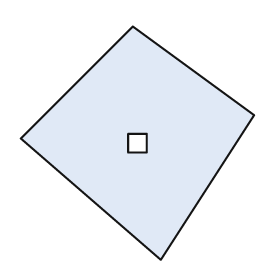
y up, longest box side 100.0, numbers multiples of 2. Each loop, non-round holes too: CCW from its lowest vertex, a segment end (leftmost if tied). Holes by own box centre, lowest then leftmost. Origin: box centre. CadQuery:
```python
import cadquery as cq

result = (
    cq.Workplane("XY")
    .moveTo(10.0, -50.0)
    .lineTo(50.0, 12.0)
    .lineTo(-2.0, 50.0)
    .lineTo(-50.0, 2.0)
    .close()
    .moveTo(-4.0, -4.0)
    .lineTo(4.0, -4.0)
    .lineTo(4.0, 4.0)
    .lineTo(-4.0, 4.0)
    .close()
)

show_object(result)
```